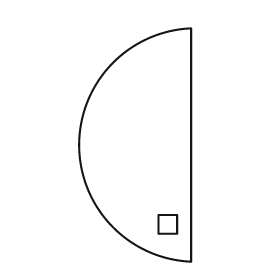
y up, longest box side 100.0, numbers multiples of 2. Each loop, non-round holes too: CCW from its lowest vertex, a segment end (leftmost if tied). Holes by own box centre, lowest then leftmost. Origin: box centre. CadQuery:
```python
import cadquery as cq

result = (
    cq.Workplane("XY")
    .moveTo(24.0, -50.0)
    .lineTo(24.0, 50.0)
    .threePointArc((-24.0, 0.0), (24.0, -50.0))
    .close()
    .moveTo(10.0, -38.0)
    .lineTo(18.0, -38.0)
    .lineTo(18.0, -30.0)
    .lineTo(10.0, -30.0)
    .close()
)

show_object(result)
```